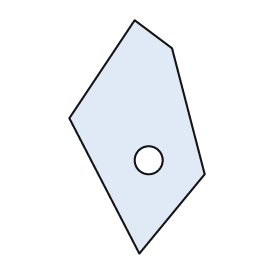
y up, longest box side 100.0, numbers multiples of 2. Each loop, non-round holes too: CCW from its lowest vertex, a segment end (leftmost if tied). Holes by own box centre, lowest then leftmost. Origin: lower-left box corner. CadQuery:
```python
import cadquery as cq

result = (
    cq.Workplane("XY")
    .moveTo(30.0, 0.0)
    .lineTo(58.0, 34.0)
    .lineTo(44.0, 88.0)
    .lineTo(28.0, 100.0)
    .lineTo(0.0, 58.0)
    .close()
    .moveTo(34.0, 40.0)
    .circle(6.0)
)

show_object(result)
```